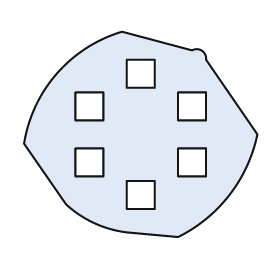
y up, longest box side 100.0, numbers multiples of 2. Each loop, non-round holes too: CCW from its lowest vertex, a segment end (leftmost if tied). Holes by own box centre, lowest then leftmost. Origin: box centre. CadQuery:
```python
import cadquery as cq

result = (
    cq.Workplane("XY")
    .moveTo(16.0, -44.0)
    .threePointArc((38.0, -26.0), (50.0, 0.0))
    .lineTo(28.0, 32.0)
    .threePointArc((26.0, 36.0), (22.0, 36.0))
    .lineTo(-8.0, 44.0)
    .threePointArc((-36.0, 26.0), (-50.0, -4.0))
    .lineTo(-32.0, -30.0)
    .threePointArc((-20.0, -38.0), (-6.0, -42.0))
    .close()
    .moveTo(-6.0, -32.0)
    .lineTo(6.0, -32.0)
    .lineTo(6.0, -20.0)
    .lineTo(-6.0, -20.0)
    .close()
    .moveTo(-28.0, -18.0)
    .lineTo(-16.0, -18.0)
    .lineTo(-16.0, -6.0)
    .lineTo(-28.0, -6.0)
    .close()
    .moveTo(16.0, -18.0)
    .lineTo(28.0, -18.0)
    .lineTo(28.0, -6.0)
    .lineTo(16.0, -6.0)
    .close()
    .moveTo(-28.0, 6.0)
    .lineTo(-16.0, 6.0)
    .lineTo(-16.0, 18.0)
    .lineTo(-28.0, 18.0)
    .close()
    .moveTo(16.0, 6.0)
    .lineTo(28.0, 6.0)
    .lineTo(28.0, 18.0)
    .lineTo(16.0, 18.0)
    .close()
    .moveTo(-6.0, 20.0)
    .lineTo(6.0, 20.0)
    .lineTo(6.0, 32.0)
    .lineTo(-6.0, 32.0)
    .close()
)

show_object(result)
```